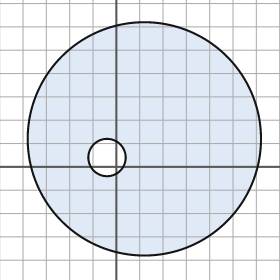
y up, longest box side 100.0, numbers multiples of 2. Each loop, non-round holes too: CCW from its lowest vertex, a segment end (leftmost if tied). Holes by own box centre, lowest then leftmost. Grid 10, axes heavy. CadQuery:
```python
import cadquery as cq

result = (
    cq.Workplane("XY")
    .moveTo(12.0, 12.0)
    .circle(50.0)
    .moveTo(-4.0, 4.0)
    .circle(8.0)
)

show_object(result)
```